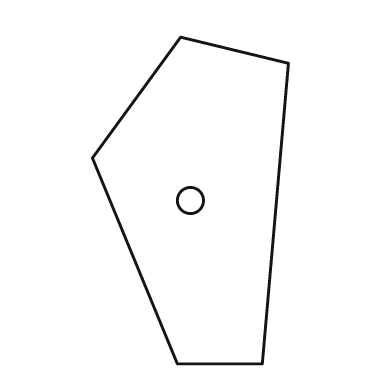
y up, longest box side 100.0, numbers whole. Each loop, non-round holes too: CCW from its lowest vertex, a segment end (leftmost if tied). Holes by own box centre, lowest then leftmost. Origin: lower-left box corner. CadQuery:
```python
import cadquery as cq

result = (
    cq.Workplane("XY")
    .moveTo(26.0, 0.0)
    .lineTo(52.0, 0.0)
    .lineTo(60.0, 92.0)
    .lineTo(27.0, 100.0)
    .lineTo(0.0, 63.0)
    .close()
    .moveTo(30.0, 50.0)
    .circle(4.0)
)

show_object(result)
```